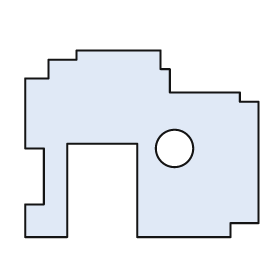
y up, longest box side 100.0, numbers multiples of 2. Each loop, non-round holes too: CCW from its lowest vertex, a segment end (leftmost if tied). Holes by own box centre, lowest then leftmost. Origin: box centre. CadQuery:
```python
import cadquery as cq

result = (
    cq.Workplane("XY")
    .moveTo(-50.0, -40.0)
    .lineTo(-32.0, -40.0)
    .lineTo(-32.0, 0.0)
    .lineTo(-2.0, 0.0)
    .lineTo(-2.0, -40.0)
    .lineTo(38.0, -40.0)
    .lineTo(38.0, -34.0)
    .lineTo(50.0, -34.0)
    .lineTo(50.0, 18.0)
    .lineTo(42.0, 18.0)
    .lineTo(42.0, 22.0)
    .lineTo(12.0, 22.0)
    .lineTo(12.0, 32.0)
    .lineTo(8.0, 32.0)
    .lineTo(8.0, 40.0)
    .lineTo(-28.0, 40.0)
    .lineTo(-28.0, 36.0)
    .lineTo(-40.0, 36.0)
    .lineTo(-40.0, 28.0)
    .lineTo(-50.0, 28.0)
    .lineTo(-50.0, -2.0)
    .lineTo(-42.0, -2.0)
    .lineTo(-42.0, -26.0)
    .lineTo(-50.0, -26.0)
    .close()
    .moveTo(14.0, -2.0)
    .circle(8.0)
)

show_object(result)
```